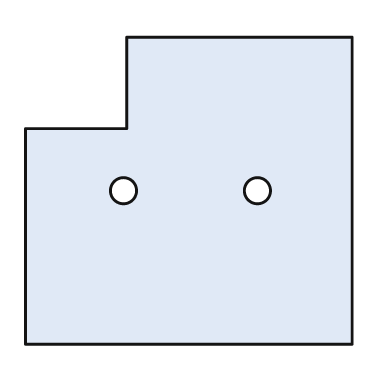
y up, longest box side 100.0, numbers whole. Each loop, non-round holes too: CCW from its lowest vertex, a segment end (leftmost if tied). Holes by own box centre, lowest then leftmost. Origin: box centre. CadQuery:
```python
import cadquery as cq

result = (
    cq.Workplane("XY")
    .moveTo(-50.0, -47.0)
    .lineTo(50.0, -47.0)
    .lineTo(50.0, 47.0)
    .lineTo(-19.0, 47.0)
    .lineTo(-19.0, 19.0)
    .lineTo(-50.0, 19.0)
    .close()
    .moveTo(-20.0, 0.0)
    .circle(4.0)
    .moveTo(21.0, 0.0)
    .circle(4.0)
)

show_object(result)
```